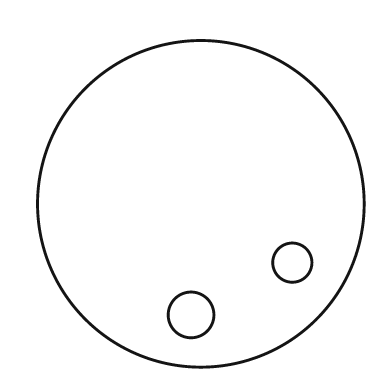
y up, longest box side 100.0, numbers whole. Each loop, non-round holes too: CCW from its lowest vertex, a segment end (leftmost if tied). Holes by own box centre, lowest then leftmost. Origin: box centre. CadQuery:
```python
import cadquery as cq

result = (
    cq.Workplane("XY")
    .moveTo(0.0, 0.0)
    .circle(50.0)
    .moveTo(-3.0, -34.0)
    .circle(7.0)
    .moveTo(28.0, -18.0)
    .circle(6.0)
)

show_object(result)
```